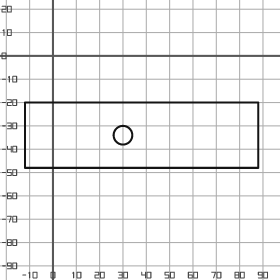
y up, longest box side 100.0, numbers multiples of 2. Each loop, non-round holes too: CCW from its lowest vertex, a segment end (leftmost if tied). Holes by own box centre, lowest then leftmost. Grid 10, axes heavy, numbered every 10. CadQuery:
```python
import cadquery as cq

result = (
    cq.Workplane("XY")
    .moveTo(-12.0, -48.0)
    .lineTo(88.0, -48.0)
    .lineTo(88.0, -20.0)
    .lineTo(-12.0, -20.0)
    .close()
    .moveTo(30.0, -34.0)
    .circle(4.0)
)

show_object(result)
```